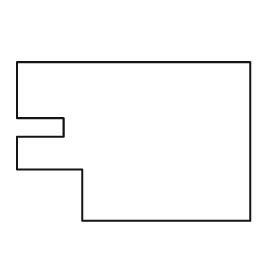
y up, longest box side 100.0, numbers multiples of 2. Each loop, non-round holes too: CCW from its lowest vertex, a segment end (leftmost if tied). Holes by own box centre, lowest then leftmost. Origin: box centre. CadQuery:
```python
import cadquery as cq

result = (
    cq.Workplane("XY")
    .moveTo(-22.0, -34.0)
    .lineTo(50.0, -34.0)
    .lineTo(50.0, 34.0)
    .lineTo(-50.0, 34.0)
    .lineTo(-50.0, 10.0)
    .lineTo(-30.0, 10.0)
    .lineTo(-30.0, 2.0)
    .lineTo(-50.0, 2.0)
    .lineTo(-50.0, -12.0)
    .lineTo(-22.0, -12.0)
    .close()
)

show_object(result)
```